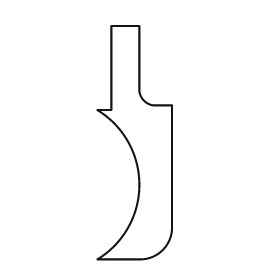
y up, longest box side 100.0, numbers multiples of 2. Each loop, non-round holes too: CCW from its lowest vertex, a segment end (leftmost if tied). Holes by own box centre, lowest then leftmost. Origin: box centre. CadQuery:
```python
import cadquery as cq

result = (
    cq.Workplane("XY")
    .moveTo(-16.0, -50.0)
    .lineTo(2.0, -50.0)
    .threePointArc((12.0, -46.0), (16.0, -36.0))
    .lineTo(16.0, 16.0)
    .lineTo(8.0, 16.0)
    .threePointArc((4.0, 18.0), (2.0, 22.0))
    .lineTo(2.0, 50.0)
    .lineTo(-10.0, 50.0)
    .lineTo(-10.0, 14.0)
    .lineTo(-16.0, 14.0)
    .threePointArc((2.0, -18.0), (-16.0, -50.0))
    .close()
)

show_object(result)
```